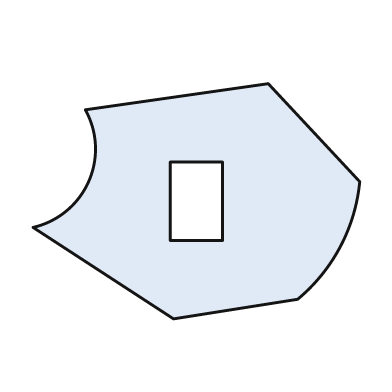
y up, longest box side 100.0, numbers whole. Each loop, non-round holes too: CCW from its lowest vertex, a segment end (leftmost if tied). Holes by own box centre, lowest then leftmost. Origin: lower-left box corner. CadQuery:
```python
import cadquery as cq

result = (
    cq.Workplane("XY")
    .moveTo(43.0, 0.0)
    .lineTo(81.0, 6.0)
    .threePointArc((94.0, 22.0), (100.0, 42.0))
    .lineTo(72.0, 72.0)
    .lineTo(16.0, 64.0)
    .threePointArc((17.0, 42.0), (0.0, 28.0))
    .close()
    .moveTo(42.0, 24.0)
    .lineTo(58.0, 24.0)
    .lineTo(58.0, 48.0)
    .lineTo(42.0, 48.0)
    .close()
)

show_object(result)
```